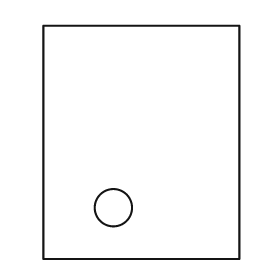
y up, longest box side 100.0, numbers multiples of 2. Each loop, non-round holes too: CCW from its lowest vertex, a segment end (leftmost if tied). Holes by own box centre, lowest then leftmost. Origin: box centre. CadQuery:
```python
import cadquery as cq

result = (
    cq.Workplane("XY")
    .moveTo(-42.0, -50.0)
    .lineTo(42.0, -50.0)
    .lineTo(42.0, 50.0)
    .lineTo(-42.0, 50.0)
    .close()
    .moveTo(-12.0, -28.0)
    .circle(8.0)
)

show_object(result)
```